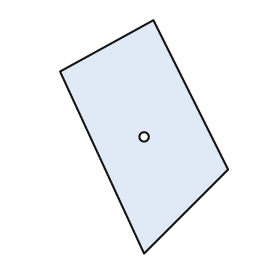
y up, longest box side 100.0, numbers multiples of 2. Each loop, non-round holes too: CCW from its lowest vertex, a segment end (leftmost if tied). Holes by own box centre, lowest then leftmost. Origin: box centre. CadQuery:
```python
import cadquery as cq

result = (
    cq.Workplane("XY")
    .moveTo(0.0, -50.0)
    .lineTo(36.0, -14.0)
    .lineTo(4.0, 50.0)
    .lineTo(-36.0, 28.0)
    .close()
    .moveTo(0.0, 0.0)
    .circle(2.0)
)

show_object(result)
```